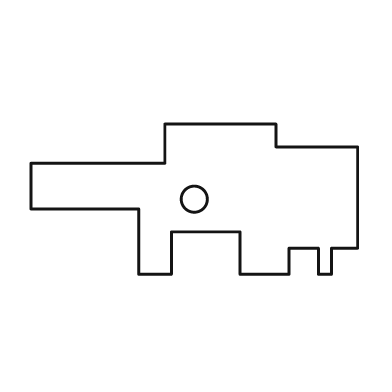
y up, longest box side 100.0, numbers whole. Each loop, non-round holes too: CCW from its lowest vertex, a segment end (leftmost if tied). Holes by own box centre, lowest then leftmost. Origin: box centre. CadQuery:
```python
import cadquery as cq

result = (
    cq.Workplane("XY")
    .moveTo(-17.0, -23.0)
    .lineTo(-7.0, -23.0)
    .lineTo(-7.0, -10.0)
    .lineTo(14.0, -10.0)
    .lineTo(14.0, -23.0)
    .lineTo(29.0, -23.0)
    .lineTo(29.0, -15.0)
    .lineTo(38.0, -15.0)
    .lineTo(38.0, -23.0)
    .lineTo(42.0, -23.0)
    .lineTo(42.0, -15.0)
    .lineTo(50.0, -15.0)
    .lineTo(50.0, 16.0)
    .lineTo(25.0, 16.0)
    .lineTo(25.0, 23.0)
    .lineTo(-9.0, 23.0)
    .lineTo(-9.0, 11.0)
    .lineTo(-50.0, 11.0)
    .lineTo(-50.0, -3.0)
    .lineTo(-17.0, -3.0)
    .close()
    .moveTo(0.0, 0.0)
    .circle(4.0)
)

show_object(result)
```